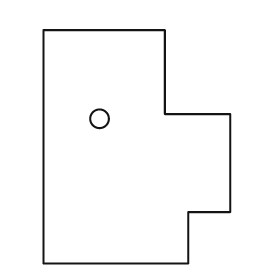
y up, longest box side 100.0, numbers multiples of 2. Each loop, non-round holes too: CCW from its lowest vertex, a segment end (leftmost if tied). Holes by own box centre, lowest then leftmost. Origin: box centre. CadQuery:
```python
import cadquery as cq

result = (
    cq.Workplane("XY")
    .moveTo(-40.0, -50.0)
    .lineTo(22.0, -50.0)
    .lineTo(22.0, -28.0)
    .lineTo(40.0, -28.0)
    .lineTo(40.0, 14.0)
    .lineTo(12.0, 14.0)
    .lineTo(12.0, 50.0)
    .lineTo(-40.0, 50.0)
    .close()
    .moveTo(-16.0, 12.0)
    .circle(4.0)
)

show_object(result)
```